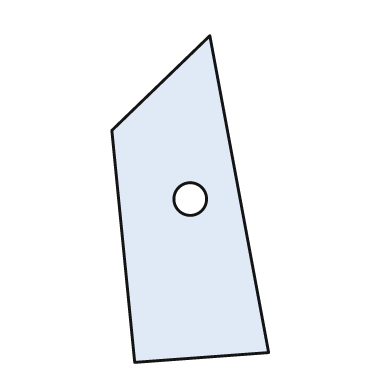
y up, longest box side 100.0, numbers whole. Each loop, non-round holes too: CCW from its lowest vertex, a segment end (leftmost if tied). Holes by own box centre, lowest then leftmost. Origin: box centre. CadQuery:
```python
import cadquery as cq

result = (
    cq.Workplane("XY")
    .moveTo(-17.0, -50.0)
    .lineTo(24.0, -47.0)
    .lineTo(6.0, 50.0)
    .lineTo(-24.0, 21.0)
    .close()
    .moveTo(0.0, 0.0)
    .circle(5.0)
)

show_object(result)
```